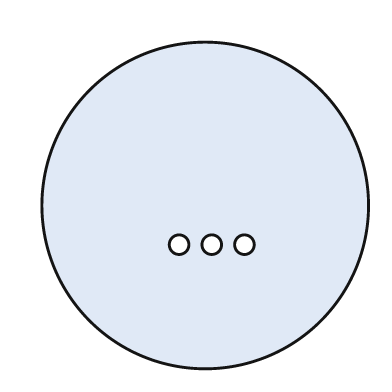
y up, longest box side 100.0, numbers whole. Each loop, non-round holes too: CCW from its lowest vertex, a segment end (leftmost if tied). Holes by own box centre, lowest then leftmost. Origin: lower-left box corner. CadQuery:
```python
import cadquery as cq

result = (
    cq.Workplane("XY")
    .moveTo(50.0, 50.0)
    .circle(50.0)
    .moveTo(42.0, 38.0)
    .circle(3.0)
    .moveTo(52.0, 38.0)
    .circle(3.0)
    .moveTo(62.0, 38.0)
    .circle(3.0)
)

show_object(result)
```